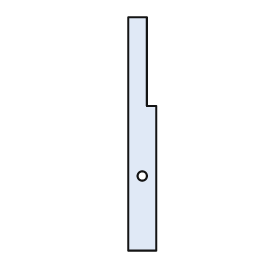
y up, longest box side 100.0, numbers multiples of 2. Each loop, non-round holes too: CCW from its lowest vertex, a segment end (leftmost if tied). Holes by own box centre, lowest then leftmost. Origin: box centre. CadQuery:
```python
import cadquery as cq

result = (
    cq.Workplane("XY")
    .moveTo(-6.0, -50.0)
    .lineTo(6.0, -50.0)
    .lineTo(6.0, 12.0)
    .lineTo(2.0, 12.0)
    .lineTo(2.0, 50.0)
    .lineTo(-6.0, 50.0)
    .close()
    .moveTo(0.0, -18.0)
    .circle(2.0)
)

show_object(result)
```